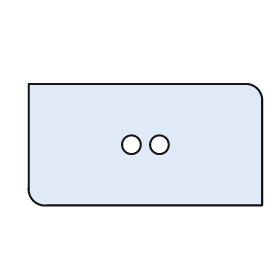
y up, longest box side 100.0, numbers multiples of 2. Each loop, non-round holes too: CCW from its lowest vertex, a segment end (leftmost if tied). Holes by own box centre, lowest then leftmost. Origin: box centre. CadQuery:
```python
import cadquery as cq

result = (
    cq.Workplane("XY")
    .moveTo(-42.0, -26.0)
    .lineTo(50.0, -26.0)
    .lineTo(50.0, 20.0)
    .threePointArc((48.0, 24.0), (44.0, 26.0))
    .lineTo(-50.0, 26.0)
    .lineTo(-50.0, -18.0)
    .threePointArc((-48.0, -24.0), (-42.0, -26.0))
    .close()
    .moveTo(-6.0, 0.0)
    .circle(4.0)
    .moveTo(6.0, 0.0)
    .circle(4.0)
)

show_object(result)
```